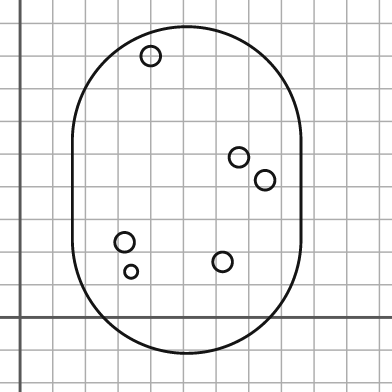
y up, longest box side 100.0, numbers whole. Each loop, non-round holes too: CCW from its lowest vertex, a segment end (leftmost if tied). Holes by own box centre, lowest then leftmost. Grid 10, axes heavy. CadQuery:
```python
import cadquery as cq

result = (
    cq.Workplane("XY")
    .moveTo(16.0, 24.0)
    .threePointArc((51.0, -11.0), (86.0, 24.0))
    .lineTo(86.0, 54.0)
    .threePointArc((51.0, 89.0), (16.0, 54.0))
    .close()
    .moveTo(34.0, 14.0)
    .circle(2.0)
    .moveTo(62.0, 17.0)
    .circle(3.0)
    .moveTo(32.0, 23.0)
    .circle(3.0)
    .moveTo(75.0, 42.0)
    .circle(3.0)
    .moveTo(67.0, 49.0)
    .circle(3.0)
    .moveTo(40.0, 80.0)
    .circle(3.0)
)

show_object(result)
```